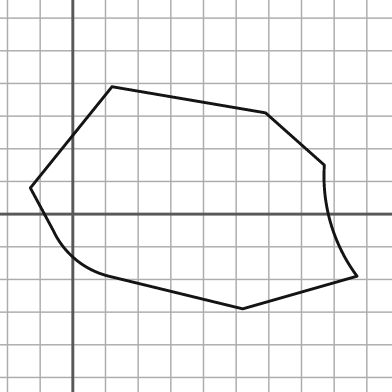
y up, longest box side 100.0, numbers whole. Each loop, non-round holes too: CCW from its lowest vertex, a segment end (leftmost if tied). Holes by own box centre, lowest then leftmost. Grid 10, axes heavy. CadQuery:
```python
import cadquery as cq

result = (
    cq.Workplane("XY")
    .moveTo(52.0, -29.0)
    .lineTo(87.0, -19.0)
    .threePointArc((79.0, -3.0), (77.0, 15.0))
    .lineTo(59.0, 31.0)
    .lineTo(12.0, 39.0)
    .lineTo(-13.0, 8.0)
    .lineTo(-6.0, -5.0)
    .threePointArc((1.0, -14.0), (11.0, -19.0))
    .close()
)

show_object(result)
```